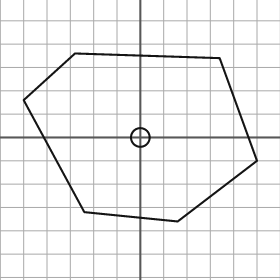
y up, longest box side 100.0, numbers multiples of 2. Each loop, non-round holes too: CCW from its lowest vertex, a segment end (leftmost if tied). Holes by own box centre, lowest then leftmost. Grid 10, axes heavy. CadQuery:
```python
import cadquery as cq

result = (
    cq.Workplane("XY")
    .moveTo(16.0, -36.0)
    .lineTo(50.0, -10.0)
    .lineTo(34.0, 34.0)
    .lineTo(-28.0, 36.0)
    .lineTo(-50.0, 16.0)
    .lineTo(-24.0, -32.0)
    .close()
    .moveTo(0.0, 0.0)
    .circle(4.0)
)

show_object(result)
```